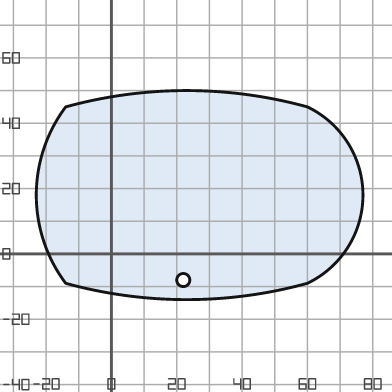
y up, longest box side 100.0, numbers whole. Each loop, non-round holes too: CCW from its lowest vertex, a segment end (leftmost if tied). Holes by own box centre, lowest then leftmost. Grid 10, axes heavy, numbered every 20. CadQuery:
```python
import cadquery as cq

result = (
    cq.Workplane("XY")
    .moveTo(-14.0, -9.0)
    .threePointArc((23.0, -14.0), (60.0, -9.0))
    .threePointArc((77.0, 18.0), (60.0, 45.0))
    .threePointArc((23.0, 50.0), (-14.0, 45.0))
    .threePointArc((-23.0, 18.0), (-14.0, -9.0))
    .close()
    .moveTo(22.0, -8.0)
    .circle(2.0)
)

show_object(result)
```